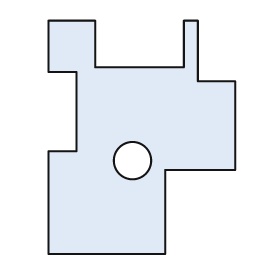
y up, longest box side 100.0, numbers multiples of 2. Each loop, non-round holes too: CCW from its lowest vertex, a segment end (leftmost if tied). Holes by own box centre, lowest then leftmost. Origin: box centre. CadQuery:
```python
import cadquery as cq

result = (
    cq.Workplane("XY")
    .moveTo(-40.0, -50.0)
    .lineTo(10.0, -50.0)
    .lineTo(10.0, -14.0)
    .lineTo(40.0, -14.0)
    .lineTo(40.0, 24.0)
    .lineTo(24.0, 24.0)
    .lineTo(24.0, 50.0)
    .lineTo(18.0, 50.0)
    .lineTo(18.0, 30.0)
    .lineTo(-20.0, 30.0)
    .lineTo(-20.0, 50.0)
    .lineTo(-40.0, 50.0)
    .lineTo(-40.0, 28.0)
    .lineTo(-28.0, 28.0)
    .lineTo(-28.0, -6.0)
    .lineTo(-40.0, -6.0)
    .close()
    .moveTo(-4.0, -10.0)
    .circle(8.0)
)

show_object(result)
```